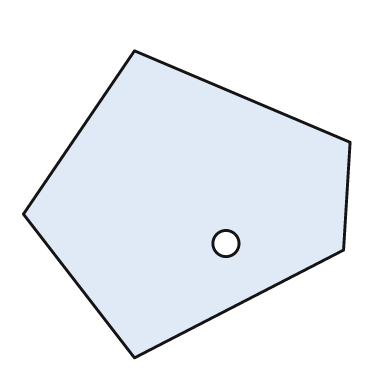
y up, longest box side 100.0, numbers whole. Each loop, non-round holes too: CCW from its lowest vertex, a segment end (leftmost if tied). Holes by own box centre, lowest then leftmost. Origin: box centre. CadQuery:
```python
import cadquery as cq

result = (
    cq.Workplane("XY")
    .moveTo(-16.0, -47.0)
    .lineTo(48.0, -14.0)
    .lineTo(50.0, 19.0)
    .lineTo(-16.0, 47.0)
    .lineTo(-50.0, -3.0)
    .close()
    .moveTo(12.0, -12.0)
    .circle(4.0)
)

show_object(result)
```